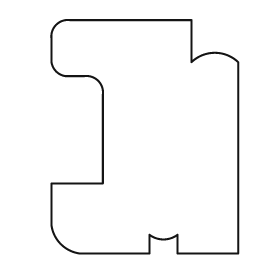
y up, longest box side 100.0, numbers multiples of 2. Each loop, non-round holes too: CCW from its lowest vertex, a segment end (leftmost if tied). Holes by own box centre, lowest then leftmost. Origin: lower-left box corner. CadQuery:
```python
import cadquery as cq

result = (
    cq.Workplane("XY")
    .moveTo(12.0, 0.0)
    .lineTo(42.0, 0.0)
    .lineTo(42.0, 8.0)
    .threePointArc((48.0, 6.0), (54.0, 8.0))
    .lineTo(54.0, 0.0)
    .lineTo(80.0, 0.0)
    .lineTo(80.0, 82.0)
    .threePointArc((70.0, 86.0), (60.0, 82.0))
    .lineTo(60.0, 100.0)
    .lineTo(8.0, 100.0)
    .threePointArc((2.0, 98.0), (0.0, 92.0))
    .lineTo(0.0, 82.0)
    .threePointArc((2.0, 78.0), (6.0, 76.0))
    .lineTo(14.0, 76.0)
    .threePointArc((20.0, 74.0), (22.0, 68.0))
    .lineTo(22.0, 30.0)
    .lineTo(0.0, 30.0)
    .lineTo(0.0, 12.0)
    .threePointArc((4.0, 4.0), (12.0, 0.0))
    .close()
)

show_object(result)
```